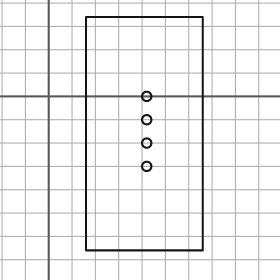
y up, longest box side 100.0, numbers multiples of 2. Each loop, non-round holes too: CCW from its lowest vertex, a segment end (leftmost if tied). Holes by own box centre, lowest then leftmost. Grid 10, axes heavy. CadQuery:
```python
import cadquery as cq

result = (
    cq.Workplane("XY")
    .moveTo(16.0, -66.0)
    .lineTo(66.0, -66.0)
    .lineTo(66.0, 34.0)
    .lineTo(16.0, 34.0)
    .close()
    .moveTo(42.0, -30.0)
    .circle(2.0)
    .moveTo(42.0, -20.0)
    .circle(2.0)
    .moveTo(42.0, -10.0)
    .circle(2.0)
    .moveTo(42.0, 0.0)
    .circle(2.0)
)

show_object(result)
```